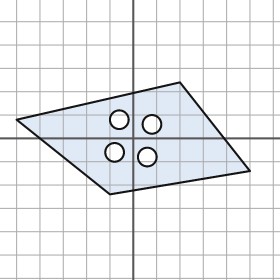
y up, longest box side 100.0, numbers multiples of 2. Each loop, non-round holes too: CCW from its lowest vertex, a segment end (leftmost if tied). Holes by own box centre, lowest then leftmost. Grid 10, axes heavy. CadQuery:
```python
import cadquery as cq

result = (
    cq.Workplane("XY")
    .moveTo(-10.0, -24.0)
    .lineTo(50.0, -14.0)
    .lineTo(20.0, 24.0)
    .lineTo(-50.0, 8.0)
    .close()
    .moveTo(6.0, -8.0)
    .circle(4.0)
    .moveTo(-8.0, -6.0)
    .circle(4.0)
    .moveTo(8.0, 6.0)
    .circle(4.0)
    .moveTo(-6.0, 8.0)
    .circle(4.0)
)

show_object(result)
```